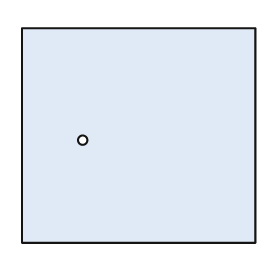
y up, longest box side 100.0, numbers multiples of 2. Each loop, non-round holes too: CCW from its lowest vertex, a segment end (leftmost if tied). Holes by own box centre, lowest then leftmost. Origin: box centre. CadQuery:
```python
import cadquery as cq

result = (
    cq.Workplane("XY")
    .moveTo(-50.0, -46.0)
    .lineTo(50.0, -46.0)
    .lineTo(50.0, 46.0)
    .lineTo(-50.0, 46.0)
    .close()
    .moveTo(-24.0, -2.0)
    .circle(2.0)
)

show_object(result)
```